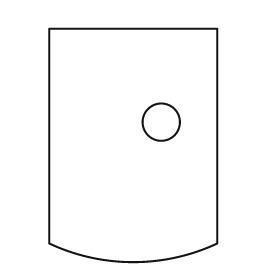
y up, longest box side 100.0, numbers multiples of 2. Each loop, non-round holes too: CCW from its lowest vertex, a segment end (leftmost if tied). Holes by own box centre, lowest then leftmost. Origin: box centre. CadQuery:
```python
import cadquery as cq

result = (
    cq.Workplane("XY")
    .moveTo(-36.0, -42.0)
    .threePointArc((0.0, -50.0), (36.0, -42.0))
    .lineTo(36.0, 50.0)
    .lineTo(-36.0, 50.0)
    .close()
    .moveTo(12.0, 10.0)
    .circle(8.0)
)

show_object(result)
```